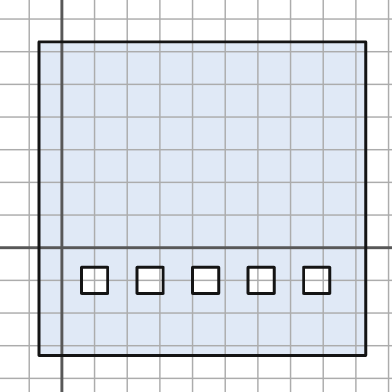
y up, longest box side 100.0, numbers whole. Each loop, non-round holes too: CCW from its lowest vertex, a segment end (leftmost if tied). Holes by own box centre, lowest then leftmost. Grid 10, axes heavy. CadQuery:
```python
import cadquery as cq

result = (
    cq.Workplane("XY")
    .moveTo(-7.0, -33.0)
    .lineTo(93.0, -33.0)
    .lineTo(93.0, 63.0)
    .lineTo(-7.0, 63.0)
    .close()
    .moveTo(6.0, -14.0)
    .lineTo(14.0, -14.0)
    .lineTo(14.0, -6.0)
    .lineTo(6.0, -6.0)
    .close()
    .moveTo(23.0, -14.0)
    .lineTo(31.0, -14.0)
    .lineTo(31.0, -6.0)
    .lineTo(23.0, -6.0)
    .close()
    .moveTo(40.0, -14.0)
    .lineTo(48.0, -14.0)
    .lineTo(48.0, -6.0)
    .lineTo(40.0, -6.0)
    .close()
    .moveTo(57.0, -14.0)
    .lineTo(65.0, -14.0)
    .lineTo(65.0, -6.0)
    .lineTo(57.0, -6.0)
    .close()
    .moveTo(74.0, -14.0)
    .lineTo(82.0, -14.0)
    .lineTo(82.0, -6.0)
    .lineTo(74.0, -6.0)
    .close()
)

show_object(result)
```